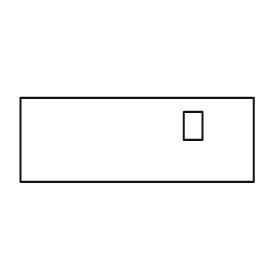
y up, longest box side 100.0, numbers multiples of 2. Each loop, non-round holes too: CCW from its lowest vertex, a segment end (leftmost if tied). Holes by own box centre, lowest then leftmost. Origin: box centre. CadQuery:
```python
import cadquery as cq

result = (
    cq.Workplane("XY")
    .moveTo(-50.0, -18.0)
    .lineTo(50.0, -18.0)
    .lineTo(50.0, 18.0)
    .lineTo(-50.0, 18.0)
    .close()
    .moveTo(20.0, 0.0)
    .lineTo(28.0, 0.0)
    .lineTo(28.0, 12.0)
    .lineTo(20.0, 12.0)
    .close()
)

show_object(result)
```